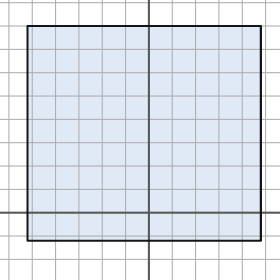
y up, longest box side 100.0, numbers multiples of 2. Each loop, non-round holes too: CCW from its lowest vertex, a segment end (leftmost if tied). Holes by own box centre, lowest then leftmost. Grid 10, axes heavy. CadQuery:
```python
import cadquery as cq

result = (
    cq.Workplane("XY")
    .moveTo(-52.0, -12.0)
    .lineTo(48.0, -12.0)
    .lineTo(48.0, 80.0)
    .lineTo(-52.0, 80.0)
    .close()
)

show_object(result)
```